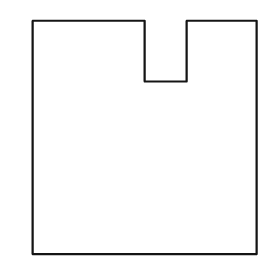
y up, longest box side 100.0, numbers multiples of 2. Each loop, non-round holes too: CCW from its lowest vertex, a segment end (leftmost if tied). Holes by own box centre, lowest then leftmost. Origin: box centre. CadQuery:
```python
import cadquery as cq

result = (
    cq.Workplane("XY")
    .moveTo(-48.0, -50.0)
    .lineTo(48.0, -50.0)
    .lineTo(48.0, 50.0)
    .lineTo(18.0, 50.0)
    .lineTo(18.0, 24.0)
    .lineTo(0.0, 24.0)
    .lineTo(0.0, 50.0)
    .lineTo(-48.0, 50.0)
    .close()
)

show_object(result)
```